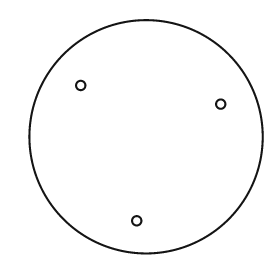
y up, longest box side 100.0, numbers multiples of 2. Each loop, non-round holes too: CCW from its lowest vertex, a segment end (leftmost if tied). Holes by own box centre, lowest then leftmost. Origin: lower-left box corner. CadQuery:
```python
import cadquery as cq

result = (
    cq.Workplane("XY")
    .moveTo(50.0, 50.0)
    .circle(50.0)
    .moveTo(46.0, 14.0)
    .circle(2.0)
    .moveTo(82.0, 64.0)
    .circle(2.0)
    .moveTo(22.0, 72.0)
    .circle(2.0)
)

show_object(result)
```